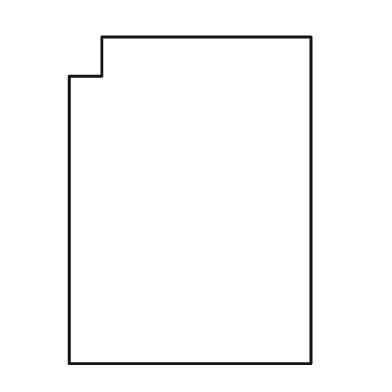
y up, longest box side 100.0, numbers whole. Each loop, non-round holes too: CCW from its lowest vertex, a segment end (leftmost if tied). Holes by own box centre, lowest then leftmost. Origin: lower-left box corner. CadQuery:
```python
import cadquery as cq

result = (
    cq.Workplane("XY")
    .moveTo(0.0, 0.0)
    .lineTo(74.0, 0.0)
    .lineTo(74.0, 100.0)
    .lineTo(10.0, 100.0)
    .lineTo(10.0, 88.0)
    .lineTo(0.0, 88.0)
    .close()
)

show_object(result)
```